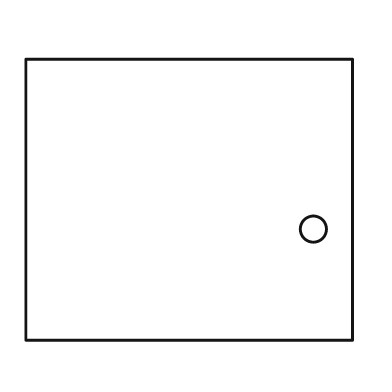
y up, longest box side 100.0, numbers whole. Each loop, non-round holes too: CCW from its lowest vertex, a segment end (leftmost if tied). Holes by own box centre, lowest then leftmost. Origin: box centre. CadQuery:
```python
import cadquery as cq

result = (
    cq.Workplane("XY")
    .moveTo(-50.0, -43.0)
    .lineTo(50.0, -43.0)
    .lineTo(50.0, 43.0)
    .lineTo(-50.0, 43.0)
    .close()
    .moveTo(38.0, -9.0)
    .circle(4.0)
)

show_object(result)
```